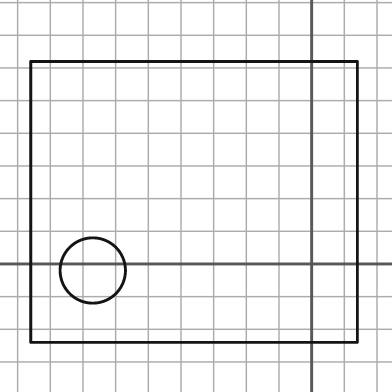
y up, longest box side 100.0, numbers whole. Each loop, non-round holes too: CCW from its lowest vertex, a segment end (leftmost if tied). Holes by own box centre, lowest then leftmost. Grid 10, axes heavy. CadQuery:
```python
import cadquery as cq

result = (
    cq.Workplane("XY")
    .moveTo(-86.0, -24.0)
    .lineTo(14.0, -24.0)
    .lineTo(14.0, 62.0)
    .lineTo(-86.0, 62.0)
    .close()
    .moveTo(-67.0, -2.0)
    .circle(10.0)
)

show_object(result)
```